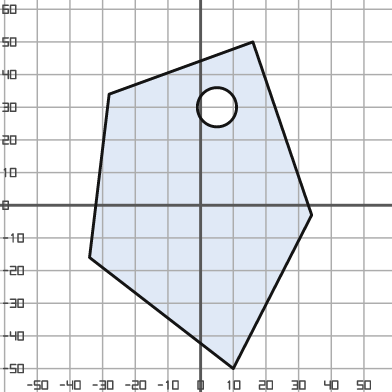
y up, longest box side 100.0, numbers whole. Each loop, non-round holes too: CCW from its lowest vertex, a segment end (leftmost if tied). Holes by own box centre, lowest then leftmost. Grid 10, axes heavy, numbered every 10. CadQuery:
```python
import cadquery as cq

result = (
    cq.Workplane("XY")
    .moveTo(10.0, -50.0)
    .lineTo(34.0, -3.0)
    .lineTo(16.0, 50.0)
    .lineTo(-28.0, 34.0)
    .lineTo(-34.0, -16.0)
    .close()
    .moveTo(5.0, 30.0)
    .circle(6.0)
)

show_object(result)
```